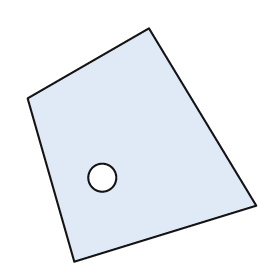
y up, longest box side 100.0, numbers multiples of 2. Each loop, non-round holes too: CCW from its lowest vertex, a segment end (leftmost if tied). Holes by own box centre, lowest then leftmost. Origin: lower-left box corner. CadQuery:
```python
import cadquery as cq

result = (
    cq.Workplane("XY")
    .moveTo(20.0, 0.0)
    .lineTo(98.0, 24.0)
    .lineTo(52.0, 100.0)
    .lineTo(0.0, 70.0)
    .close()
    .moveTo(32.0, 36.0)
    .circle(6.0)
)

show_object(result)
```